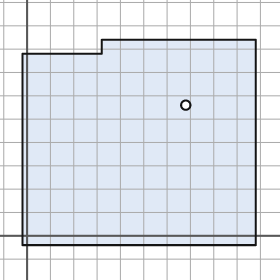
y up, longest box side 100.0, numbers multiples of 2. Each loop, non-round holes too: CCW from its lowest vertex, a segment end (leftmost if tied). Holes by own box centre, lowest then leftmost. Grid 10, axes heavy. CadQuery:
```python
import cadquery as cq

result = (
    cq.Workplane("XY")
    .moveTo(-2.0, -4.0)
    .lineTo(98.0, -4.0)
    .lineTo(98.0, 84.0)
    .lineTo(32.0, 84.0)
    .lineTo(32.0, 78.0)
    .lineTo(-2.0, 78.0)
    .close()
    .moveTo(68.0, 56.0)
    .circle(2.0)
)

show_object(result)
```